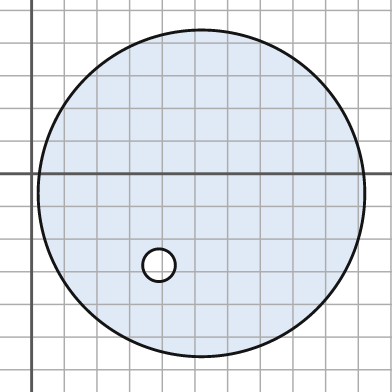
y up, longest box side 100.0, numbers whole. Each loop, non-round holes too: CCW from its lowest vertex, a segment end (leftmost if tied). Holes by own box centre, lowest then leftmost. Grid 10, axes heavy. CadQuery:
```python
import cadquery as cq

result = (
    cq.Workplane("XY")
    .moveTo(52.0, -6.0)
    .circle(50.0)
    .moveTo(39.0, -28.0)
    .circle(5.0)
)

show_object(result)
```